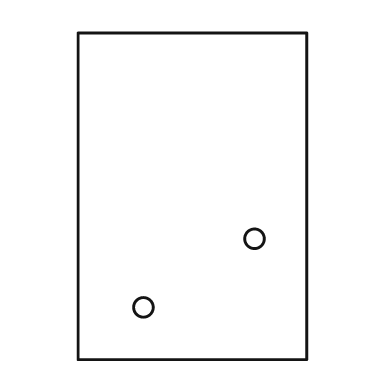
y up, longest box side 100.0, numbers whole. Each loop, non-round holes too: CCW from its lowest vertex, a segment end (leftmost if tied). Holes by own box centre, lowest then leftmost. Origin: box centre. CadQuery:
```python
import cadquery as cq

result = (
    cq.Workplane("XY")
    .moveTo(-35.0, -50.0)
    .lineTo(35.0, -50.0)
    .lineTo(35.0, 50.0)
    .lineTo(-35.0, 50.0)
    .close()
    .moveTo(-15.0, -34.0)
    .circle(3.0)
    .moveTo(19.0, -13.0)
    .circle(3.0)
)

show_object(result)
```